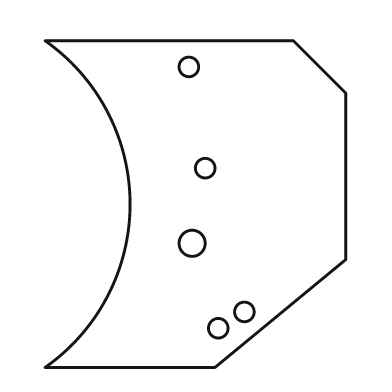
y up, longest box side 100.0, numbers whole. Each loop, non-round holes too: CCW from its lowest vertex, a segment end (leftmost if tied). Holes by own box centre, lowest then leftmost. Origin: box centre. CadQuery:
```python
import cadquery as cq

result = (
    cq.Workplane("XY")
    .moveTo(-46.0, -50.0)
    .lineTo(6.0, -50.0)
    .lineTo(46.0, -17.0)
    .lineTo(46.0, 34.0)
    .lineTo(30.0, 50.0)
    .lineTo(-46.0, 50.0)
    .threePointArc((-20.0, 0.0), (-46.0, -50.0))
    .close()
    .moveTo(7.0, -38.0)
    .circle(3.0)
    .moveTo(15.0, -33.0)
    .circle(3.0)
    .moveTo(-1.0, -12.0)
    .circle(4.0)
    .moveTo(3.0, 11.0)
    .circle(3.0)
    .moveTo(-2.0, 42.0)
    .circle(3.0)
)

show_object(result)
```